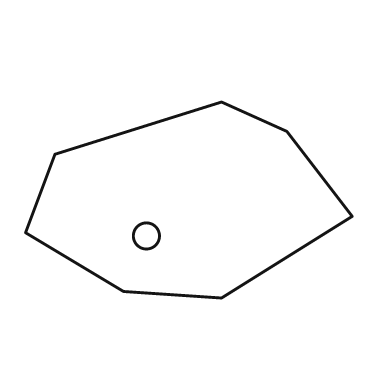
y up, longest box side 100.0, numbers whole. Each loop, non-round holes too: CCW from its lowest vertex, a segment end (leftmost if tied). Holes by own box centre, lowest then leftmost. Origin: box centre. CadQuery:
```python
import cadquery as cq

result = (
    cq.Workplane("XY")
    .moveTo(10.0, -30.0)
    .lineTo(50.0, -5.0)
    .lineTo(30.0, 21.0)
    .lineTo(10.0, 30.0)
    .lineTo(-41.0, 14.0)
    .lineTo(-50.0, -10.0)
    .lineTo(-20.0, -28.0)
    .close()
    .moveTo(-13.0, -11.0)
    .circle(4.0)
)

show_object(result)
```